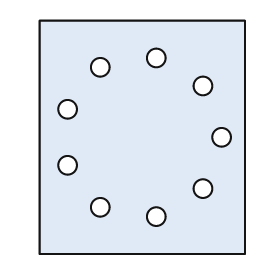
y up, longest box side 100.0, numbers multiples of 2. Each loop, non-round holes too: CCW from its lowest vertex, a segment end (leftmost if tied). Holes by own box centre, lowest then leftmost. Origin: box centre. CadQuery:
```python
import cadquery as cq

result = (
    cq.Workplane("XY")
    .moveTo(-44.0, -50.0)
    .lineTo(44.0, -50.0)
    .lineTo(44.0, 50.0)
    .lineTo(-44.0, 50.0)
    .close()
    .moveTo(6.0, -34.0)
    .circle(4.0)
    .moveTo(-18.0, -30.0)
    .circle(4.0)
    .moveTo(26.0, -22.0)
    .circle(4.0)
    .moveTo(-32.0, -12.0)
    .circle(4.0)
    .moveTo(34.0, 0.0)
    .circle(4.0)
    .moveTo(-32.0, 12.0)
    .circle(4.0)
    .moveTo(26.0, 22.0)
    .circle(4.0)
    .moveTo(-18.0, 30.0)
    .circle(4.0)
    .moveTo(6.0, 34.0)
    .circle(4.0)
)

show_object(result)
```